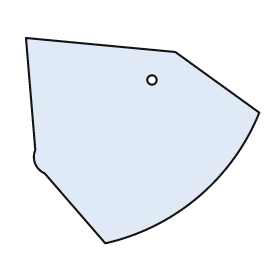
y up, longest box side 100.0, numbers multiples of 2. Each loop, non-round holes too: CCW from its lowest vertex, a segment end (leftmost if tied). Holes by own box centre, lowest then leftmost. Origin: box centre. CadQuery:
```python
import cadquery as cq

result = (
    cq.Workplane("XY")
    .moveTo(-16.0, -44.0)
    .threePointArc((24.0, -24.0), (50.0, 12.0))
    .lineTo(14.0, 38.0)
    .lineTo(-50.0, 44.0)
    .lineTo(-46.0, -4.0)
    .threePointArc((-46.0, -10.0), (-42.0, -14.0))
    .close()
    .moveTo(4.0, 26.0)
    .circle(2.0)
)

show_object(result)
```